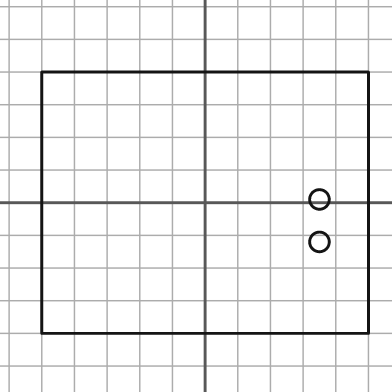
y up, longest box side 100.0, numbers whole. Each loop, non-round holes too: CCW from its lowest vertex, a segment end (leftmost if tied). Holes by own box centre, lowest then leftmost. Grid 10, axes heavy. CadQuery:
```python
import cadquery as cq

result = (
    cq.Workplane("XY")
    .moveTo(-50.0, -40.0)
    .lineTo(50.0, -40.0)
    .lineTo(50.0, 40.0)
    .lineTo(-50.0, 40.0)
    .close()
    .moveTo(35.0, -12.0)
    .circle(3.0)
    .moveTo(35.0, 1.0)
    .circle(3.0)
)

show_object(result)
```